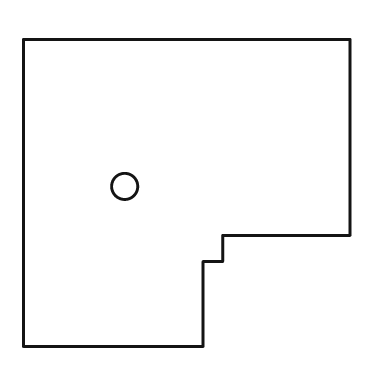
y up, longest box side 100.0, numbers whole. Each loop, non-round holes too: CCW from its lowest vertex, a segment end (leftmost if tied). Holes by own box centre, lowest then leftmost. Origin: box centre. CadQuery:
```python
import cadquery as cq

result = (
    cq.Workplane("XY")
    .moveTo(-50.0, -47.0)
    .lineTo(5.0, -47.0)
    .lineTo(5.0, -21.0)
    .lineTo(11.0, -21.0)
    .lineTo(11.0, -13.0)
    .lineTo(50.0, -13.0)
    .lineTo(50.0, 47.0)
    .lineTo(-50.0, 47.0)
    .close()
    .moveTo(-19.0, 2.0)
    .circle(4.0)
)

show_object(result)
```